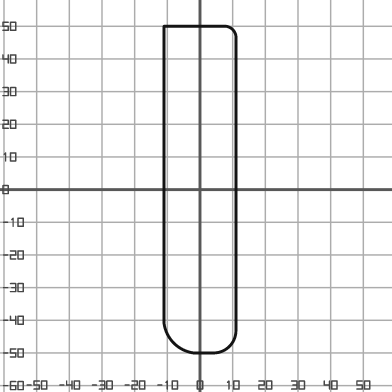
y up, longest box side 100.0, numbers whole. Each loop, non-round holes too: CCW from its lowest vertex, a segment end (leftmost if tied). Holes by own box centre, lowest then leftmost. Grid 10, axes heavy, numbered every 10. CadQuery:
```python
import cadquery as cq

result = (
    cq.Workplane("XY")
    .moveTo(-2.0, -50.0)
    .lineTo(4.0, -50.0)
    .threePointArc((9.0, -48.0), (11.0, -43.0))
    .lineTo(11.0, 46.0)
    .threePointArc((10.0, 49.0), (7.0, 50.0))
    .lineTo(-11.0, 50.0)
    .lineTo(-11.0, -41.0)
    .threePointArc((-8.0, -47.0), (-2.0, -50.0))
    .close()
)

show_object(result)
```